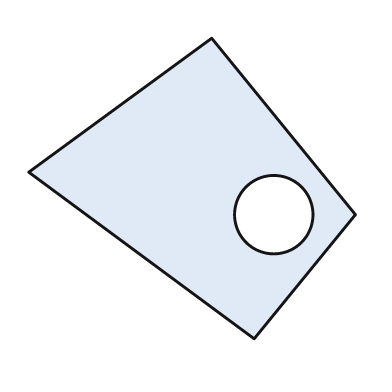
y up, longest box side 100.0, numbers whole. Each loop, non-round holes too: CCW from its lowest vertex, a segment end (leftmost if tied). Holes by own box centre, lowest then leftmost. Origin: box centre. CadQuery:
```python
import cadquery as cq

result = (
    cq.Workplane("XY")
    .moveTo(19.0, -46.0)
    .lineTo(50.0, -8.0)
    .lineTo(6.0, 46.0)
    .lineTo(-50.0, 5.0)
    .close()
    .moveTo(25.0, -8.0)
    .circle(12.0)
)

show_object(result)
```